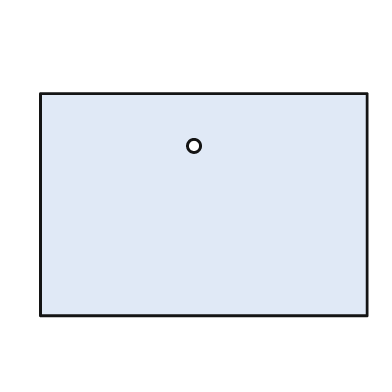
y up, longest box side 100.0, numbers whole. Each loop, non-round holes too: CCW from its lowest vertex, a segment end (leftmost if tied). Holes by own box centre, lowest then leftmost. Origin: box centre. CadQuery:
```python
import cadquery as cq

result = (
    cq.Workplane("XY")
    .moveTo(-50.0, -34.0)
    .lineTo(50.0, -34.0)
    .lineTo(50.0, 34.0)
    .lineTo(-50.0, 34.0)
    .close()
    .moveTo(-3.0, 18.0)
    .circle(2.0)
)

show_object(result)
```